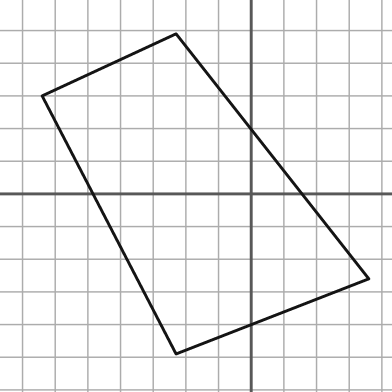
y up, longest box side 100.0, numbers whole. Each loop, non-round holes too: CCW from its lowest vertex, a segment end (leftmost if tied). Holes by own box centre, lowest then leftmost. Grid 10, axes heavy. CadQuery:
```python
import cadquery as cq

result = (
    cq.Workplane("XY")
    .moveTo(-23.0, -49.0)
    .lineTo(36.0, -26.0)
    .lineTo(-23.0, 49.0)
    .lineTo(-64.0, 30.0)
    .close()
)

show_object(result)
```